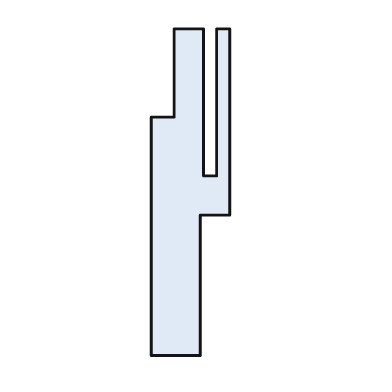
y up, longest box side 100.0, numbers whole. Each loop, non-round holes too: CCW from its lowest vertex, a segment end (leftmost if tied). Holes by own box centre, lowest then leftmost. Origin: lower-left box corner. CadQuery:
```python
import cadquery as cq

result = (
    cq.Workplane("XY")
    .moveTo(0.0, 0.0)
    .lineTo(15.0, 0.0)
    .lineTo(15.0, 43.0)
    .lineTo(24.0, 43.0)
    .lineTo(24.0, 100.0)
    .lineTo(20.0, 100.0)
    .lineTo(20.0, 55.0)
    .lineTo(16.0, 55.0)
    .lineTo(16.0, 100.0)
    .lineTo(7.0, 100.0)
    .lineTo(7.0, 73.0)
    .lineTo(0.0, 73.0)
    .close()
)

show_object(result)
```